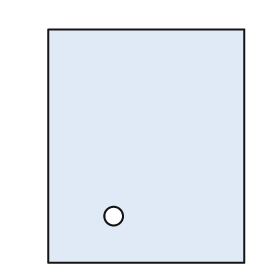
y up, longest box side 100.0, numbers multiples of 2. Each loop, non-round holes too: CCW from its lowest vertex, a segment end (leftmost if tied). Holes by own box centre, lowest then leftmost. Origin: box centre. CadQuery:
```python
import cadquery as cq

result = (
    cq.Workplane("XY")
    .moveTo(-42.0, -50.0)
    .lineTo(42.0, -50.0)
    .lineTo(42.0, 50.0)
    .lineTo(-42.0, 50.0)
    .close()
    .moveTo(-14.0, -30.0)
    .circle(4.0)
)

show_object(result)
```